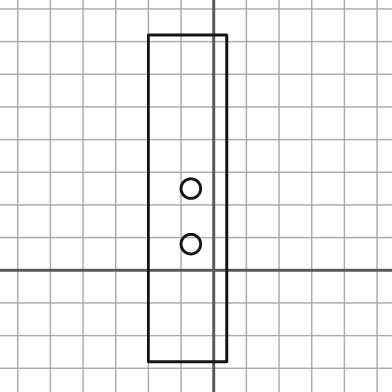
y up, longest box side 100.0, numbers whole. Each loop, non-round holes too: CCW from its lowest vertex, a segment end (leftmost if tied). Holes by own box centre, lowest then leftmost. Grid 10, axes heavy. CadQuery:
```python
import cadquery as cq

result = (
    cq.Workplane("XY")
    .moveTo(-20.0, -28.0)
    .lineTo(4.0, -28.0)
    .lineTo(4.0, 72.0)
    .lineTo(-20.0, 72.0)
    .close()
    .moveTo(-7.0, 8.0)
    .circle(3.0)
    .moveTo(-7.0, 25.0)
    .circle(3.0)
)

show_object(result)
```